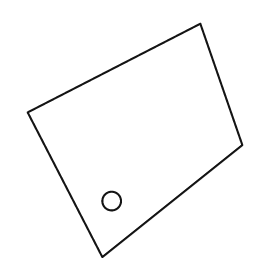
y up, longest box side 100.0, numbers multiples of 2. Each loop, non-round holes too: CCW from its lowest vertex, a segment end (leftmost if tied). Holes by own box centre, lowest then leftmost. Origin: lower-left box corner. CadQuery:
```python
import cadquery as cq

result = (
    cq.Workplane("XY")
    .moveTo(32.0, 0.0)
    .lineTo(92.0, 48.0)
    .lineTo(74.0, 100.0)
    .lineTo(0.0, 62.0)
    .close()
    .moveTo(36.0, 24.0)
    .circle(4.0)
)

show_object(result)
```